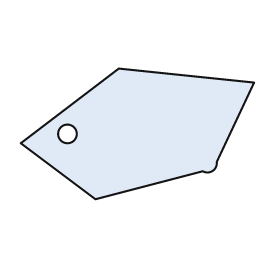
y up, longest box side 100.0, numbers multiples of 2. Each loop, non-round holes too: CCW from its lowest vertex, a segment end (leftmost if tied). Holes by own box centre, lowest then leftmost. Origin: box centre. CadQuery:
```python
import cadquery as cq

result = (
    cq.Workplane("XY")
    .moveTo(-18.0, -28.0)
    .lineTo(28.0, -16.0)
    .threePointArc((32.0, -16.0), (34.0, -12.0))
    .lineTo(50.0, 22.0)
    .lineTo(-8.0, 28.0)
    .lineTo(-50.0, -4.0)
    .close()
    .moveTo(-30.0, 0.0)
    .circle(4.0)
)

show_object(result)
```